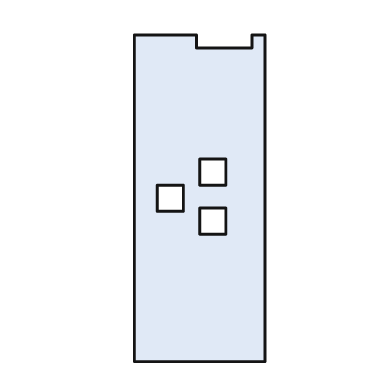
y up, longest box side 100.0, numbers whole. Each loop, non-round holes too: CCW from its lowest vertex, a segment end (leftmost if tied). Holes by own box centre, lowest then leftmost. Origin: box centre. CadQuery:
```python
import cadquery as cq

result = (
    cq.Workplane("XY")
    .moveTo(-20.0, -50.0)
    .lineTo(20.0, -50.0)
    .lineTo(20.0, 50.0)
    .lineTo(16.0, 50.0)
    .lineTo(16.0, 46.0)
    .lineTo(-1.0, 46.0)
    .lineTo(-1.0, 50.0)
    .lineTo(-20.0, 50.0)
    .close()
    .moveTo(0.0, -11.0)
    .lineTo(8.0, -11.0)
    .lineTo(8.0, -3.0)
    .lineTo(0.0, -3.0)
    .close()
    .moveTo(-13.0, -4.0)
    .lineTo(-5.0, -4.0)
    .lineTo(-5.0, 4.0)
    .lineTo(-13.0, 4.0)
    .close()
    .moveTo(0.0, 4.0)
    .lineTo(8.0, 4.0)
    .lineTo(8.0, 12.0)
    .lineTo(0.0, 12.0)
    .close()
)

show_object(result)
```